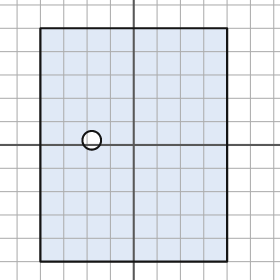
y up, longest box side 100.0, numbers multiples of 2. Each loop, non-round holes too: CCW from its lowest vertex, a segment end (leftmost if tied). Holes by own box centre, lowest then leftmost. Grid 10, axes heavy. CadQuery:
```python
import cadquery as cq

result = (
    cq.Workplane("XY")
    .moveTo(-40.0, -50.0)
    .lineTo(40.0, -50.0)
    .lineTo(40.0, 50.0)
    .lineTo(-40.0, 50.0)
    .close()
    .moveTo(-18.0, 2.0)
    .circle(4.0)
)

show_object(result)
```